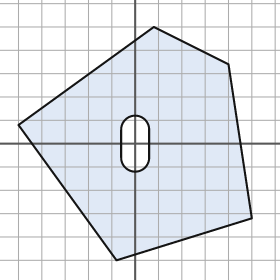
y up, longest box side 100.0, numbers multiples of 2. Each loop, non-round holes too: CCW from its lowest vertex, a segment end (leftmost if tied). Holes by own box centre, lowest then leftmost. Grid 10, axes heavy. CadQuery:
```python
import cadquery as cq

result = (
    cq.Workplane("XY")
    .moveTo(-8.0, -50.0)
    .lineTo(50.0, -32.0)
    .lineTo(40.0, 34.0)
    .lineTo(8.0, 50.0)
    .lineTo(-50.0, 8.0)
    .close()
    .moveTo(-6.0, -6.0)
    .threePointArc((0.0, -12.0), (6.0, -6.0))
    .lineTo(6.0, 6.0)
    .threePointArc((0.0, 12.0), (-6.0, 6.0))
    .close()
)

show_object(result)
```